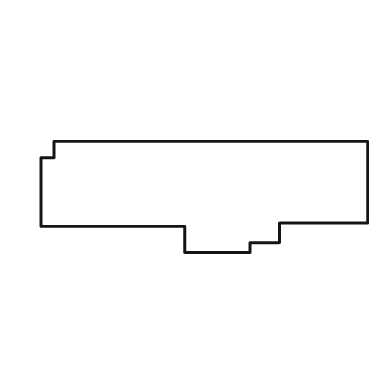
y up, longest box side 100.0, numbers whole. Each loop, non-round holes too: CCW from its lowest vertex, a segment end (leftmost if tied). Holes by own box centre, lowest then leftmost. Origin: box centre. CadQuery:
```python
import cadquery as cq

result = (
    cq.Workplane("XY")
    .moveTo(-6.0, -17.0)
    .lineTo(14.0, -17.0)
    .lineTo(14.0, -14.0)
    .lineTo(23.0, -14.0)
    .lineTo(23.0, -8.0)
    .lineTo(50.0, -8.0)
    .lineTo(50.0, 17.0)
    .lineTo(-46.0, 17.0)
    .lineTo(-46.0, 12.0)
    .lineTo(-50.0, 12.0)
    .lineTo(-50.0, -9.0)
    .lineTo(-6.0, -9.0)
    .close()
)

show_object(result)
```